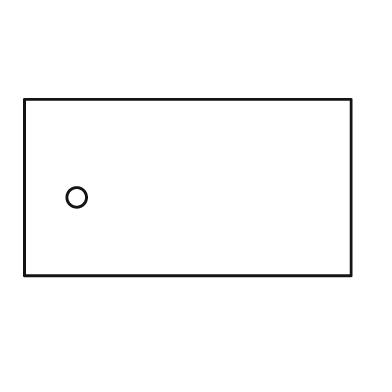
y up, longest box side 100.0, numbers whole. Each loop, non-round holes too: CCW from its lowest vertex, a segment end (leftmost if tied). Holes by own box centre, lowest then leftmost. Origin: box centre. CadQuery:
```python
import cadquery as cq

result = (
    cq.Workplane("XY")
    .moveTo(-50.0, -27.0)
    .lineTo(50.0, -27.0)
    .lineTo(50.0, 27.0)
    .lineTo(-50.0, 27.0)
    .close()
    .moveTo(-34.0, -3.0)
    .circle(3.0)
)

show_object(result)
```